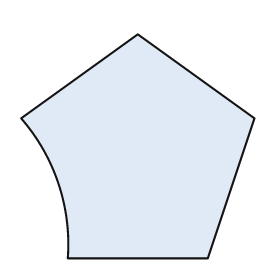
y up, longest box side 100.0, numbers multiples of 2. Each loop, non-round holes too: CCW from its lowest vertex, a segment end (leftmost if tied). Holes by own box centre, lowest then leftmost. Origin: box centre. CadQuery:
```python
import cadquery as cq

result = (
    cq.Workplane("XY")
    .moveTo(-30.0, -48.0)
    .lineTo(30.0, -48.0)
    .lineTo(50.0, 12.0)
    .lineTo(0.0, 48.0)
    .lineTo(-50.0, 12.0)
    .threePointArc((-34.0, -16.0), (-30.0, -48.0))
    .close()
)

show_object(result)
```